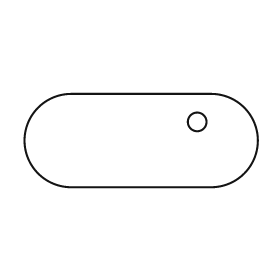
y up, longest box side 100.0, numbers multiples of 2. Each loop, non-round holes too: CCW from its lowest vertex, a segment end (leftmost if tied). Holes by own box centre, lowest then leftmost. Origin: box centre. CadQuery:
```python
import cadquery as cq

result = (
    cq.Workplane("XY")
    .moveTo(-30.0, -20.0)
    .lineTo(30.0, -20.0)
    .threePointArc((50.0, 0.0), (30.0, 20.0))
    .lineTo(-30.0, 20.0)
    .threePointArc((-50.0, 0.0), (-30.0, -20.0))
    .close()
    .moveTo(24.0, 8.0)
    .circle(4.0)
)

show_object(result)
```